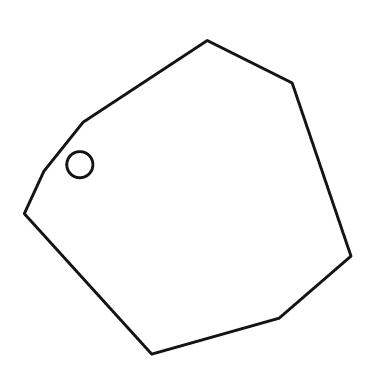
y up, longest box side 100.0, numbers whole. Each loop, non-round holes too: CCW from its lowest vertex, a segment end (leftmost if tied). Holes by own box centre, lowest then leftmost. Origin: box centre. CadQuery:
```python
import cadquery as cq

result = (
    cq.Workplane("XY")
    .moveTo(-11.0, -48.0)
    .lineTo(28.0, -37.0)
    .lineTo(50.0, -18.0)
    .lineTo(32.0, 35.0)
    .lineTo(6.0, 48.0)
    .lineTo(-32.0, 23.0)
    .lineTo(-44.0, 8.0)
    .lineTo(-50.0, -5.0)
    .close()
    .moveTo(-33.0, 10.0)
    .circle(4.0)
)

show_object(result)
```